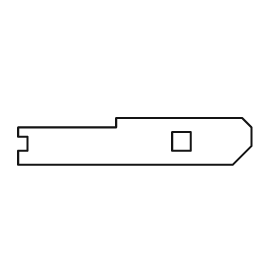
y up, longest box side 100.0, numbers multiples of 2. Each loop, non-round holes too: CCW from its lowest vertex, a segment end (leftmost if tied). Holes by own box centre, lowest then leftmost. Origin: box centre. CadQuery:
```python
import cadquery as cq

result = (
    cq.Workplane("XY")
    .moveTo(-50.0, -10.0)
    .lineTo(42.0, -10.0)
    .lineTo(50.0, -2.0)
    .lineTo(50.0, 6.0)
    .lineTo(46.0, 10.0)
    .lineTo(-8.0, 10.0)
    .lineTo(-8.0, 6.0)
    .lineTo(-50.0, 6.0)
    .lineTo(-50.0, 2.0)
    .lineTo(-46.0, 2.0)
    .lineTo(-46.0, -4.0)
    .lineTo(-50.0, -4.0)
    .close()
    .moveTo(16.0, -4.0)
    .lineTo(24.0, -4.0)
    .lineTo(24.0, 4.0)
    .lineTo(16.0, 4.0)
    .close()
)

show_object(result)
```